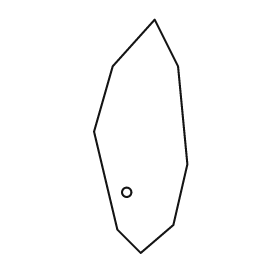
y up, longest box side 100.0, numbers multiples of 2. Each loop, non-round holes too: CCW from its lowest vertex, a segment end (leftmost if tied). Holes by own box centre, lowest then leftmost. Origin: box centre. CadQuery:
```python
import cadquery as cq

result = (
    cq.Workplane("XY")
    .moveTo(0.0, -50.0)
    .lineTo(14.0, -38.0)
    .lineTo(20.0, -12.0)
    .lineTo(16.0, 30.0)
    .lineTo(6.0, 50.0)
    .lineTo(-12.0, 30.0)
    .lineTo(-20.0, 2.0)
    .lineTo(-10.0, -40.0)
    .close()
    .moveTo(-6.0, -24.0)
    .circle(2.0)
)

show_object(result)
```